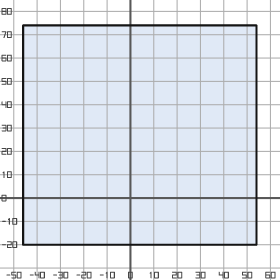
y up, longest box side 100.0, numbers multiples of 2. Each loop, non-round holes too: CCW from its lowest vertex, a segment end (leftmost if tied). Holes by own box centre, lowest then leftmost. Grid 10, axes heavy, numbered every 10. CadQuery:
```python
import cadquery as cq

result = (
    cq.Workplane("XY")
    .moveTo(-46.0, -20.0)
    .lineTo(54.0, -20.0)
    .lineTo(54.0, 74.0)
    .lineTo(-46.0, 74.0)
    .close()
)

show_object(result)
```